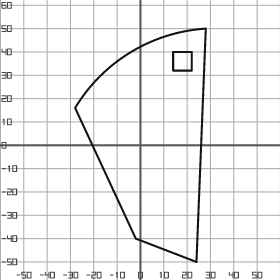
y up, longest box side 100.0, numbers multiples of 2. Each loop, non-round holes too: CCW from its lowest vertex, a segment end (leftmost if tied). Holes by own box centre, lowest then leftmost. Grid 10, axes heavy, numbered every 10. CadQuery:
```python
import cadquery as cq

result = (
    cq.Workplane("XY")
    .moveTo(24.0, -50.0)
    .lineTo(28.0, 50.0)
    .threePointArc((-4.0, 40.0), (-28.0, 16.0))
    .lineTo(-2.0, -40.0)
    .close()
    .moveTo(14.0, 32.0)
    .lineTo(22.0, 32.0)
    .lineTo(22.0, 40.0)
    .lineTo(14.0, 40.0)
    .close()
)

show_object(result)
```